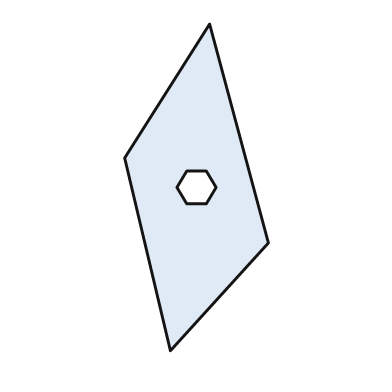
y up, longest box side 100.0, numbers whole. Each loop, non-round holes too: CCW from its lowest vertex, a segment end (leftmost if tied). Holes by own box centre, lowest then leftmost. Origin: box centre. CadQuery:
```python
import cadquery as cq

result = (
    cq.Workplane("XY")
    .moveTo(-8.0, -50.0)
    .lineTo(22.0, -17.0)
    .lineTo(4.0, 50.0)
    .lineTo(-22.0, 9.0)
    .close()
    .moveTo(-3.0, -5.0)
    .lineTo(3.0, -5.0)
    .lineTo(6.0, 0.0)
    .lineTo(3.0, 5.0)
    .lineTo(-3.0, 5.0)
    .lineTo(-6.0, 0.0)
    .close()
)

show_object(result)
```